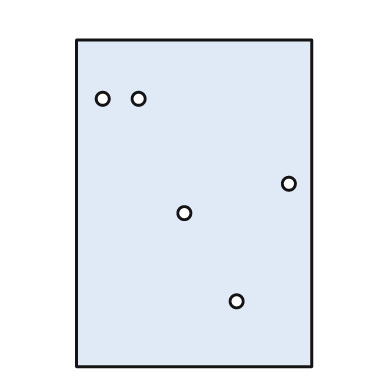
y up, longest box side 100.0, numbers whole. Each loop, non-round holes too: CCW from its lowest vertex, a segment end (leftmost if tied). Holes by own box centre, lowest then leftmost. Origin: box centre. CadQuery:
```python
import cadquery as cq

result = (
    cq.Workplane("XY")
    .moveTo(-36.0, -50.0)
    .lineTo(36.0, -50.0)
    .lineTo(36.0, 50.0)
    .lineTo(-36.0, 50.0)
    .close()
    .moveTo(13.0, -30.0)
    .circle(2.0)
    .moveTo(-3.0, -3.0)
    .circle(2.0)
    .moveTo(29.0, 6.0)
    .circle(2.0)
    .moveTo(-28.0, 32.0)
    .circle(2.0)
    .moveTo(-17.0, 32.0)
    .circle(2.0)
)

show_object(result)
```